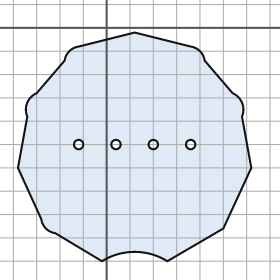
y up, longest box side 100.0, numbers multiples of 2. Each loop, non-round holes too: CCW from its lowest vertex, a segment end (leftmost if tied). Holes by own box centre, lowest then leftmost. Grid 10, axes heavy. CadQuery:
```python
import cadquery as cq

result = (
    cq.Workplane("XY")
    .moveTo(-2.0, -100.0)
    .threePointArc((12.0, -96.0), (26.0, -100.0))
    .lineTo(50.0, -86.0)
    .lineTo(62.0, -60.0)
    .lineTo(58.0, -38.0)
    .threePointArc((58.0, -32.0), (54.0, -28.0))
    .lineTo(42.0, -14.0)
    .threePointArc((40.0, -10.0), (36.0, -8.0))
    .lineTo(12.0, -2.0)
    .lineTo(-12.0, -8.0)
    .threePointArc((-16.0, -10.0), (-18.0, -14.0))
    .lineTo(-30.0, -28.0)
    .threePointArc((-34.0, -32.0), (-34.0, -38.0))
    .lineTo(-38.0, -60.0)
    .lineTo(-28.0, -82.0)
    .threePointArc((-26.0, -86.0), (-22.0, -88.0))
    .close()
    .moveTo(-12.0, -50.0)
    .circle(2.0)
    .moveTo(4.0, -50.0)
    .circle(2.0)
    .moveTo(20.0, -50.0)
    .circle(2.0)
    .moveTo(36.0, -50.0)
    .circle(2.0)
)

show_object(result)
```